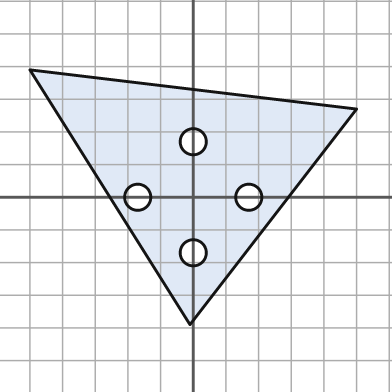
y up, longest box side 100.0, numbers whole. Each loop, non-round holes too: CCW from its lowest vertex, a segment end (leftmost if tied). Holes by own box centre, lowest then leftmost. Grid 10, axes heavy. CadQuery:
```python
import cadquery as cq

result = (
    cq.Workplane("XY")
    .moveTo(-1.0, -39.0)
    .lineTo(50.0, 27.0)
    .lineTo(-50.0, 39.0)
    .close()
    .moveTo(0.0, -17.0)
    .circle(4.0)
    .moveTo(-17.0, 0.0)
    .circle(4.0)
    .moveTo(17.0, 0.0)
    .circle(4.0)
    .moveTo(0.0, 17.0)
    .circle(4.0)
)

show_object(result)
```